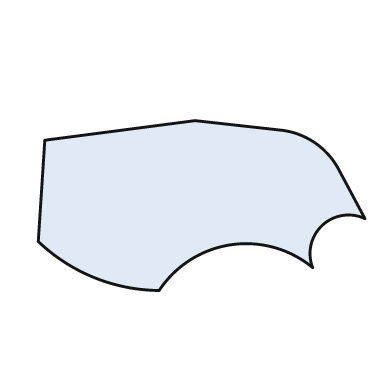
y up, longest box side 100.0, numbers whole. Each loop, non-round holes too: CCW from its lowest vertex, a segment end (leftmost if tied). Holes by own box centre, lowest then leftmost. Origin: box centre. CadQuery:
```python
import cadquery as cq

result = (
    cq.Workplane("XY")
    .moveTo(-13.0, -26.0)
    .threePointArc((9.0, -12.0), (34.0, -19.0))
    .threePointArc((37.0, -6.0), (50.0, -4.0))
    .lineTo(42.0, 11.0)
    .threePointArc((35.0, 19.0), (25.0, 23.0))
    .lineTo(-2.0, 26.0)
    .lineTo(-48.0, 20.0)
    .lineTo(-50.0, -11.0)
    .threePointArc((-33.0, -22.0), (-13.0, -26.0))
    .close()
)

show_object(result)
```